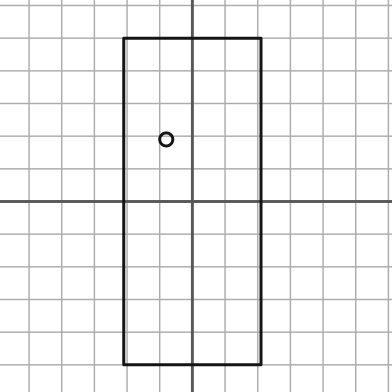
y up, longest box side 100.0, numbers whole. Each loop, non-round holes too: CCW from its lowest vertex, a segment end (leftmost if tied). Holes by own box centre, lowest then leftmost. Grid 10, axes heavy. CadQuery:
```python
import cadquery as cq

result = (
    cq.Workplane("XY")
    .moveTo(-21.0, -50.0)
    .lineTo(21.0, -50.0)
    .lineTo(21.0, 50.0)
    .lineTo(-21.0, 50.0)
    .close()
    .moveTo(-8.0, 19.0)
    .circle(2.0)
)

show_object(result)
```